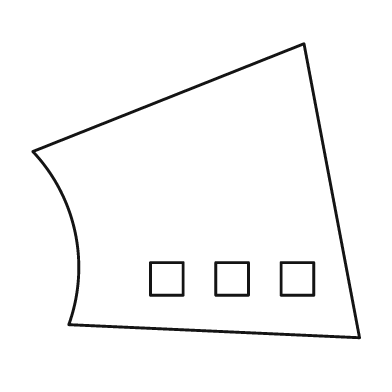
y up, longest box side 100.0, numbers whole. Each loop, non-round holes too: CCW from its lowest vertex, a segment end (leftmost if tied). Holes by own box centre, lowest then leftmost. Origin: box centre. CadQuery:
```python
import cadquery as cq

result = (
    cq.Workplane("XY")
    .moveTo(50.0, -45.0)
    .lineTo(33.0, 45.0)
    .lineTo(-50.0, 12.0)
    .threePointArc((-37.0, -13.0), (-39.0, -41.0))
    .close()
    .moveTo(-14.0, -32.0)
    .lineTo(-4.0, -32.0)
    .lineTo(-4.0, -22.0)
    .lineTo(-14.0, -22.0)
    .close()
    .moveTo(6.0, -32.0)
    .lineTo(16.0, -32.0)
    .lineTo(16.0, -22.0)
    .lineTo(6.0, -22.0)
    .close()
    .moveTo(26.0, -32.0)
    .lineTo(36.0, -32.0)
    .lineTo(36.0, -22.0)
    .lineTo(26.0, -22.0)
    .close()
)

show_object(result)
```